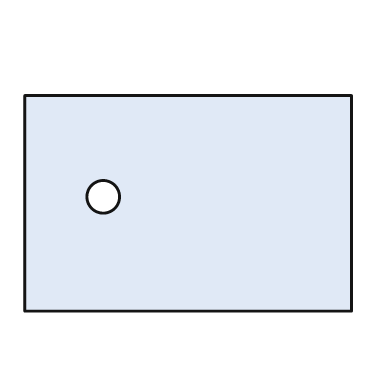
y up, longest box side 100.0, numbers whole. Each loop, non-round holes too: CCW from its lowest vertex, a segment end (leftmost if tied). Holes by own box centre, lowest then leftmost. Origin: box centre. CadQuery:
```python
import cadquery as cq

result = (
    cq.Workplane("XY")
    .moveTo(-50.0, -33.0)
    .lineTo(50.0, -33.0)
    .lineTo(50.0, 33.0)
    .lineTo(-50.0, 33.0)
    .close()
    .moveTo(-26.0, 2.0)
    .circle(5.0)
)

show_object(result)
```